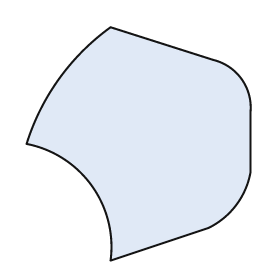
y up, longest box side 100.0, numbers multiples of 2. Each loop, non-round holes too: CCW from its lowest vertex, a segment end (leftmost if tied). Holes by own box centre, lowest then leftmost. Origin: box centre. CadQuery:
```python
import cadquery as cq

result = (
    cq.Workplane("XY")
    .moveTo(-12.0, -50.0)
    .lineTo(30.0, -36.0)
    .threePointArc((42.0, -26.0), (48.0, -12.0))
    .lineTo(48.0, 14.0)
    .threePointArc((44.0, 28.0), (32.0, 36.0))
    .lineTo(-12.0, 50.0)
    .threePointArc((-34.0, 28.0), (-48.0, 0.0))
    .threePointArc((-20.0, -18.0), (-12.0, -50.0))
    .close()
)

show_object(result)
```